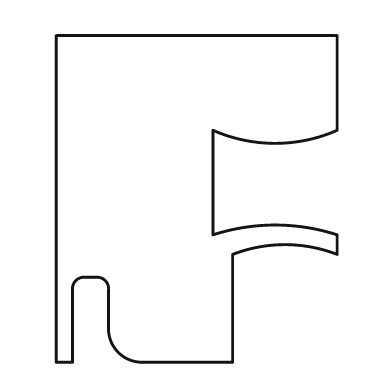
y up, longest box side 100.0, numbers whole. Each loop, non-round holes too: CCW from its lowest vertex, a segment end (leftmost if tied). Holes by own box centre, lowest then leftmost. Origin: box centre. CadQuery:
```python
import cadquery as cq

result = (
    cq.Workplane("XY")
    .moveTo(-43.0, -50.0)
    .lineTo(-38.0, -50.0)
    .lineTo(-38.0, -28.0)
    .threePointArc((-37.0, -25.0), (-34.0, -24.0))
    .lineTo(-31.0, -24.0)
    .threePointArc((-28.0, -25.0), (-27.0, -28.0))
    .lineTo(-27.0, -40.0)
    .threePointArc((-24.0, -47.0), (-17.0, -50.0))
    .lineTo(11.0, -50.0)
    .lineTo(11.0, -17.0)
    .threePointArc((27.0, -14.0), (43.0, -17.0))
    .lineTo(43.0, -11.0)
    .threePointArc((24.0, -8.0), (5.0, -11.0))
    .lineTo(5.0, 21.0)
    .threePointArc((24.0, 17.0), (43.0, 21.0))
    .lineTo(43.0, 50.0)
    .lineTo(-43.0, 50.0)
    .close()
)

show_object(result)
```